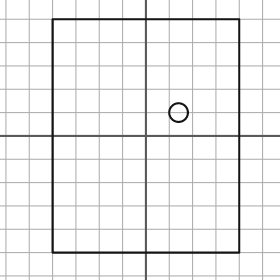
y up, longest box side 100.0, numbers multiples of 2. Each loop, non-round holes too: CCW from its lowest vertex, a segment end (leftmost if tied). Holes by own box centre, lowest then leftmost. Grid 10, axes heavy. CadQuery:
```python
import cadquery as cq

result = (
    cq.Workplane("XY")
    .moveTo(-40.0, -50.0)
    .lineTo(40.0, -50.0)
    .lineTo(40.0, 50.0)
    .lineTo(-40.0, 50.0)
    .close()
    .moveTo(14.0, 10.0)
    .circle(4.0)
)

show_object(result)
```